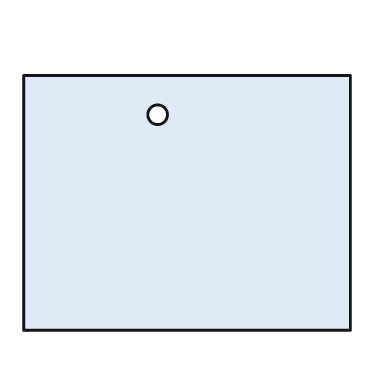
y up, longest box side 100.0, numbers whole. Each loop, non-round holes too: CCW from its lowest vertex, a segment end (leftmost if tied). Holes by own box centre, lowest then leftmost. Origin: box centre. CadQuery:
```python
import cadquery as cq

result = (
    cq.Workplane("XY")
    .moveTo(-50.0, -39.0)
    .lineTo(50.0, -39.0)
    .lineTo(50.0, 39.0)
    .lineTo(-50.0, 39.0)
    .close()
    .moveTo(-9.0, 27.0)
    .circle(3.0)
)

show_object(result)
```